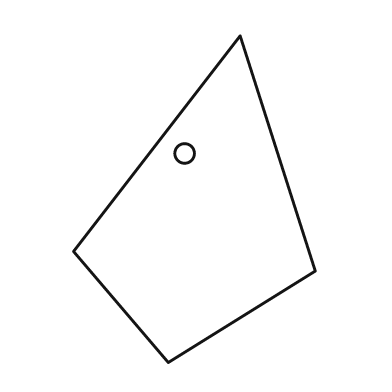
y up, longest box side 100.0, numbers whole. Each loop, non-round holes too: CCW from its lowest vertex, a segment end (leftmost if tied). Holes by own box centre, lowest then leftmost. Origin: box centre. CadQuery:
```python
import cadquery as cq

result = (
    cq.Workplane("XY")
    .moveTo(-8.0, -50.0)
    .lineTo(37.0, -22.0)
    .lineTo(14.0, 50.0)
    .lineTo(-37.0, -16.0)
    .close()
    .moveTo(-3.0, 14.0)
    .circle(3.0)
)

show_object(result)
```